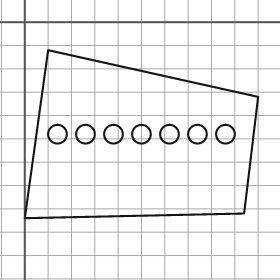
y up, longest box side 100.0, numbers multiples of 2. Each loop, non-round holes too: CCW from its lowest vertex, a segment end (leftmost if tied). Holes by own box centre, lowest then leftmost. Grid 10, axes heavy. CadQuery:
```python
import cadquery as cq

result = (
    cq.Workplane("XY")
    .moveTo(0.0, -84.0)
    .lineTo(94.0, -82.0)
    .lineTo(100.0, -32.0)
    .lineTo(10.0, -12.0)
    .close()
    .moveTo(14.0, -48.0)
    .circle(4.0)
    .moveTo(26.0, -48.0)
    .circle(4.0)
    .moveTo(38.0, -48.0)
    .circle(4.0)
    .moveTo(50.0, -48.0)
    .circle(4.0)
    .moveTo(62.0, -48.0)
    .circle(4.0)
    .moveTo(74.0, -48.0)
    .circle(4.0)
    .moveTo(86.0, -48.0)
    .circle(4.0)
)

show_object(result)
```